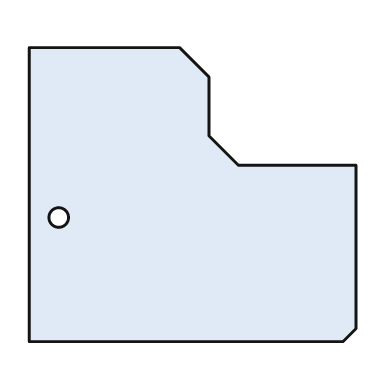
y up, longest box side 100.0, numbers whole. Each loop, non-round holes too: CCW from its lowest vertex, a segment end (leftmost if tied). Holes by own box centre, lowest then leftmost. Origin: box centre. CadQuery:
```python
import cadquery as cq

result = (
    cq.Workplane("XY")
    .moveTo(-50.0, -45.0)
    .lineTo(46.0, -45.0)
    .lineTo(50.0, -41.0)
    .lineTo(50.0, 9.0)
    .lineTo(14.0, 9.0)
    .lineTo(5.0, 18.0)
    .lineTo(5.0, 36.0)
    .lineTo(-4.0, 45.0)
    .lineTo(-50.0, 45.0)
    .close()
    .moveTo(-41.0, -7.0)
    .circle(3.0)
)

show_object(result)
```